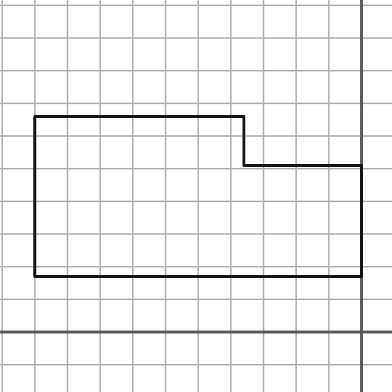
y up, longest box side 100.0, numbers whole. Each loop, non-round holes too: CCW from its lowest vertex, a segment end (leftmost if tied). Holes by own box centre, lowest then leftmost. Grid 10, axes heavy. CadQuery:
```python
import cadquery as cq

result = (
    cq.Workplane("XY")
    .moveTo(-100.0, 17.0)
    .lineTo(0.0, 17.0)
    .lineTo(0.0, 51.0)
    .lineTo(-36.0, 51.0)
    .lineTo(-36.0, 66.0)
    .lineTo(-100.0, 66.0)
    .close()
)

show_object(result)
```